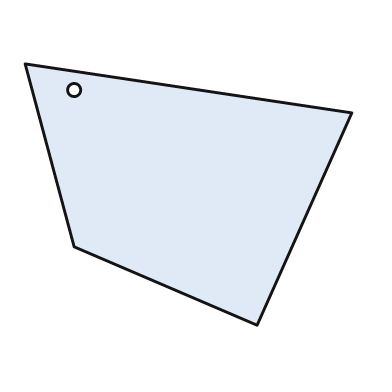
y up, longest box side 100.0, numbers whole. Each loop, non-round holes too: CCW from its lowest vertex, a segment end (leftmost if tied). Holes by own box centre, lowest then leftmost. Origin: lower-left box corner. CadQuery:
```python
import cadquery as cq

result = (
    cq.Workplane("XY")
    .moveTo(71.0, 0.0)
    .lineTo(100.0, 65.0)
    .lineTo(0.0, 80.0)
    .lineTo(15.0, 24.0)
    .close()
    .moveTo(15.0, 72.0)
    .circle(2.0)
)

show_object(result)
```